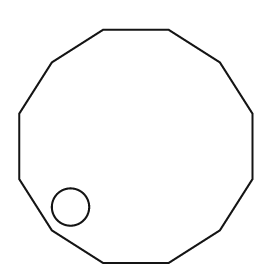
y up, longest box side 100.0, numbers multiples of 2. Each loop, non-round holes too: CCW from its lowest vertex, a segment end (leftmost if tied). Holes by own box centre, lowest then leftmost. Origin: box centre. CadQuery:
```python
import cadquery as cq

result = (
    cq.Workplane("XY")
    .moveTo(-14.0, -50.0)
    .lineTo(14.0, -50.0)
    .lineTo(36.0, -36.0)
    .lineTo(50.0, -14.0)
    .lineTo(50.0, 14.0)
    .lineTo(36.0, 36.0)
    .lineTo(14.0, 50.0)
    .lineTo(-14.0, 50.0)
    .lineTo(-36.0, 36.0)
    .lineTo(-50.0, 14.0)
    .lineTo(-50.0, -14.0)
    .lineTo(-36.0, -36.0)
    .close()
    .moveTo(-28.0, -26.0)
    .circle(8.0)
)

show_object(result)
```